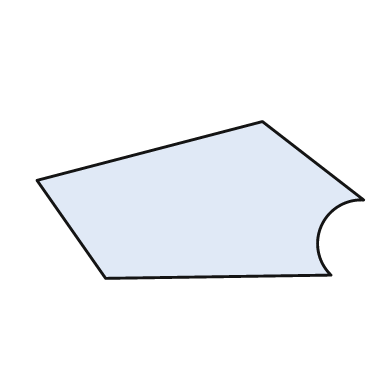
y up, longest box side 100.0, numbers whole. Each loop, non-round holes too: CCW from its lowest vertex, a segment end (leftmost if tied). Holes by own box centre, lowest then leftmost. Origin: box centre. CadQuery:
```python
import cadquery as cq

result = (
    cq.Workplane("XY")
    .moveTo(-29.0, -24.0)
    .lineTo(40.0, -23.0)
    .threePointArc((37.0, -8.0), (50.0, 0.0))
    .lineTo(19.0, 24.0)
    .lineTo(-50.0, 6.0)
    .close()
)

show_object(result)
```